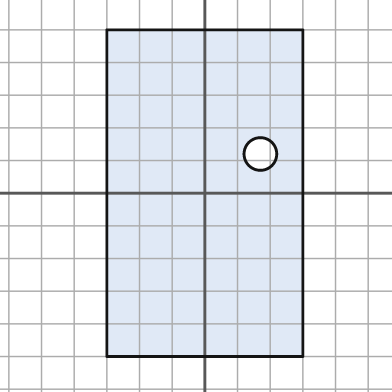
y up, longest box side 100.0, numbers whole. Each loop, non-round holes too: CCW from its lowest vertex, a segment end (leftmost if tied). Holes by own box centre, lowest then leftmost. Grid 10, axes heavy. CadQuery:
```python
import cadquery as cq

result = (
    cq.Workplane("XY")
    .moveTo(-30.0, -50.0)
    .lineTo(30.0, -50.0)
    .lineTo(30.0, 50.0)
    .lineTo(-30.0, 50.0)
    .close()
    .moveTo(17.0, 12.0)
    .circle(5.0)
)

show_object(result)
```